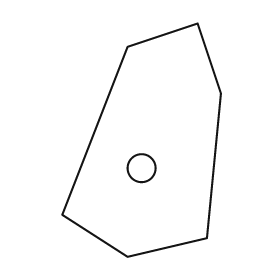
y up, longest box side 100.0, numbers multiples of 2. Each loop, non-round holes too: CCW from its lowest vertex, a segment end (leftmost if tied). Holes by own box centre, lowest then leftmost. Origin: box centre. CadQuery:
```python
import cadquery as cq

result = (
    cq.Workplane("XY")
    .moveTo(-6.0, -50.0)
    .lineTo(28.0, -42.0)
    .lineTo(34.0, 20.0)
    .lineTo(24.0, 50.0)
    .lineTo(-6.0, 40.0)
    .lineTo(-34.0, -32.0)
    .close()
    .moveTo(0.0, -12.0)
    .circle(6.0)
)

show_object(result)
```